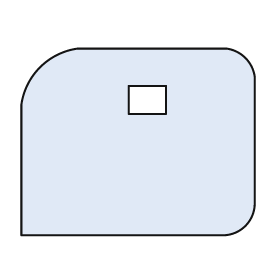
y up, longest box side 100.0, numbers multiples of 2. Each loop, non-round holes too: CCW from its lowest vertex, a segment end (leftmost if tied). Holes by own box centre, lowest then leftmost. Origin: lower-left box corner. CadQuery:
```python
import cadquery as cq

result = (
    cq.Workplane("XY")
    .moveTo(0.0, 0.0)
    .lineTo(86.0, 0.0)
    .threePointArc((96.0, 4.0), (100.0, 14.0))
    .lineTo(100.0, 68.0)
    .threePointArc((96.0, 76.0), (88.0, 80.0))
    .lineTo(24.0, 80.0)
    .threePointArc((8.0, 72.0), (0.0, 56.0))
    .close()
    .moveTo(46.0, 52.0)
    .lineTo(62.0, 52.0)
    .lineTo(62.0, 64.0)
    .lineTo(46.0, 64.0)
    .close()
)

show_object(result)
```